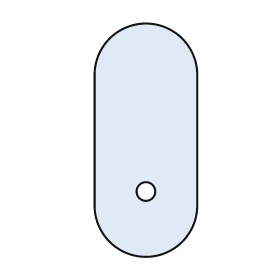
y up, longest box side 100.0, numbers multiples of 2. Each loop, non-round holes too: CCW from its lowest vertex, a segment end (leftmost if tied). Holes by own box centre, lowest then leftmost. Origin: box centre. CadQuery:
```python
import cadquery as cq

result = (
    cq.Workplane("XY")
    .moveTo(-22.0, -28.0)
    .threePointArc((0.0, -50.0), (22.0, -28.0))
    .lineTo(22.0, 28.0)
    .threePointArc((0.0, 50.0), (-22.0, 28.0))
    .close()
    .moveTo(0.0, -22.0)
    .circle(4.0)
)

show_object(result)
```